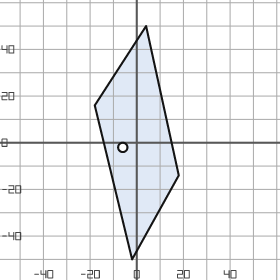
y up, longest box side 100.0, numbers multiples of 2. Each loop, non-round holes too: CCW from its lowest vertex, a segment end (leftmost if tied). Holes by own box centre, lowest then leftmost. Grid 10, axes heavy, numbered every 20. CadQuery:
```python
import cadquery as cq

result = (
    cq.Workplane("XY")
    .moveTo(-2.0, -50.0)
    .lineTo(18.0, -14.0)
    .lineTo(4.0, 50.0)
    .lineTo(-18.0, 16.0)
    .close()
    .moveTo(-6.0, -2.0)
    .circle(2.0)
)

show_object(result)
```